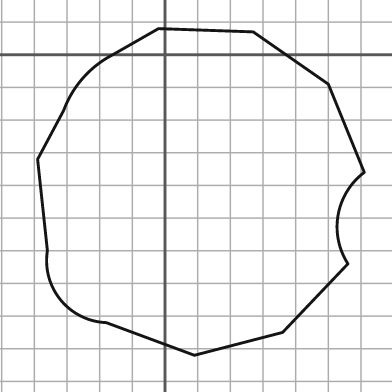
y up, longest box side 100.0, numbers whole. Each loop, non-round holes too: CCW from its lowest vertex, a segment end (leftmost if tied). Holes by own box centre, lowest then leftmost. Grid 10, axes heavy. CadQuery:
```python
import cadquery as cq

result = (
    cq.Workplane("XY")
    .moveTo(9.0, -92.0)
    .lineTo(36.0, -85.0)
    .lineTo(56.0, -64.0)
    .threePointArc((53.0, -49.0), (61.0, -36.0))
    .lineTo(50.0, -9.0)
    .lineTo(27.0, 7.0)
    .lineTo(-2.0, 8.0)
    .lineTo(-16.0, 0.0)
    .threePointArc((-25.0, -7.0), (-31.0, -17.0))
    .lineTo(-39.0, -32.0)
    .lineTo(-36.0, -60.0)
    .threePointArc((-32.0, -75.0), (-18.0, -82.0))
    .close()
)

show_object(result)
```